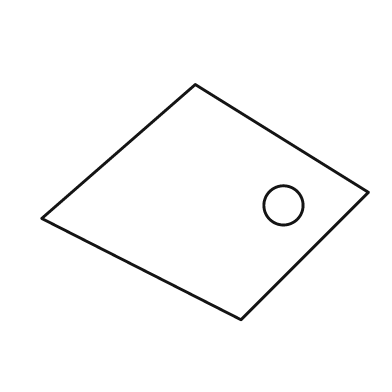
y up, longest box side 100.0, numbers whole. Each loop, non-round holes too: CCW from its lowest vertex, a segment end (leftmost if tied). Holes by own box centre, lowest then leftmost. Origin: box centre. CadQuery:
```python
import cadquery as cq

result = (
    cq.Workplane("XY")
    .moveTo(11.0, -36.0)
    .lineTo(50.0, 3.0)
    .lineTo(-3.0, 36.0)
    .lineTo(-50.0, -5.0)
    .close()
    .moveTo(24.0, -1.0)
    .circle(6.0)
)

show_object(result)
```